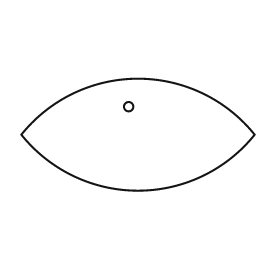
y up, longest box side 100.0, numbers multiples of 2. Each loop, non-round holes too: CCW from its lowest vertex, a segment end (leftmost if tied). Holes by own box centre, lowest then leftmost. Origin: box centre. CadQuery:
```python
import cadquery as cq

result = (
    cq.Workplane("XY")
    .moveTo(-50.0, 0.0)
    .threePointArc((0.0, -24.0), (50.0, 0.0))
    .threePointArc((0.0, 24.0), (-50.0, 0.0))
    .close()
    .moveTo(-4.0, 12.0)
    .circle(2.0)
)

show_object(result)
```